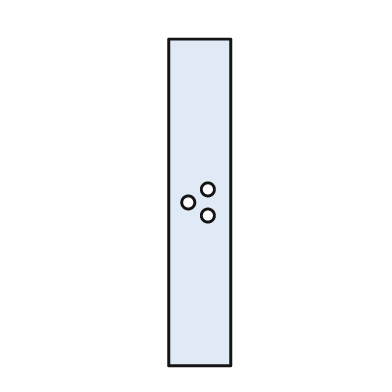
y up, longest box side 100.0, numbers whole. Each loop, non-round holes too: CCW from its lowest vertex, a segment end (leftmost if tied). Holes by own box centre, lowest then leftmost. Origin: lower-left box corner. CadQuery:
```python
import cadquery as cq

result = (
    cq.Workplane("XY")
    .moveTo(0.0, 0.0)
    .lineTo(19.0, 0.0)
    .lineTo(19.0, 100.0)
    .lineTo(0.0, 100.0)
    .close()
    .moveTo(12.0, 46.0)
    .circle(2.0)
    .moveTo(6.0, 50.0)
    .circle(2.0)
    .moveTo(12.0, 54.0)
    .circle(2.0)
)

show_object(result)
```